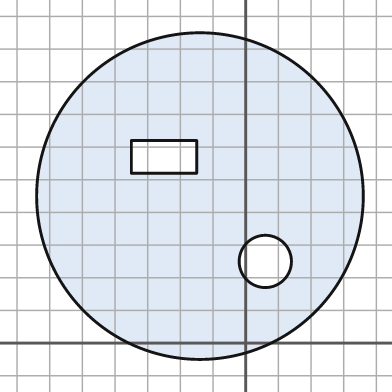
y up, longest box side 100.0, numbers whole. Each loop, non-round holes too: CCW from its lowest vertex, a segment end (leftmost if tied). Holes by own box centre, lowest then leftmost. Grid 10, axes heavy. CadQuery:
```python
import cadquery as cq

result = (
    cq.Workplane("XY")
    .moveTo(-14.0, 45.0)
    .circle(50.0)
    .moveTo(6.0, 25.0)
    .circle(8.0)
    .moveTo(-35.0, 52.0)
    .lineTo(-15.0, 52.0)
    .lineTo(-15.0, 62.0)
    .lineTo(-35.0, 62.0)
    .close()
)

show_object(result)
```